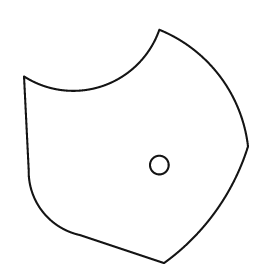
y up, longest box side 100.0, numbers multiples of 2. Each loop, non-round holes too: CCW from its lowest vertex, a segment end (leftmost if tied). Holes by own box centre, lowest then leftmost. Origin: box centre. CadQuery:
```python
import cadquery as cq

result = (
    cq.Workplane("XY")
    .moveTo(12.0, -50.0)
    .threePointArc((34.0, -28.0), (48.0, 0.0))
    .threePointArc((36.0, 30.0), (10.0, 50.0))
    .threePointArc((-14.0, 26.0), (-48.0, 30.0))
    .lineTo(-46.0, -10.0)
    .threePointArc((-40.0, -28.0), (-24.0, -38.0))
    .close()
    .moveTo(10.0, -8.0)
    .circle(4.0)
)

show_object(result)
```